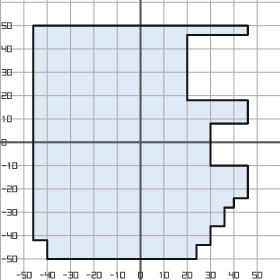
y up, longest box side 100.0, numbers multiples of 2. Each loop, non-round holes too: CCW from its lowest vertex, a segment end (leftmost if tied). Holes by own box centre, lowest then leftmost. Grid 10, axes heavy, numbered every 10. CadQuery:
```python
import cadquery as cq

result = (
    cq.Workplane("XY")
    .moveTo(-40.0, -50.0)
    .lineTo(24.0, -50.0)
    .lineTo(24.0, -44.0)
    .lineTo(30.0, -44.0)
    .lineTo(30.0, -36.0)
    .lineTo(36.0, -36.0)
    .lineTo(36.0, -28.0)
    .lineTo(40.0, -28.0)
    .lineTo(40.0, -24.0)
    .lineTo(46.0, -24.0)
    .lineTo(46.0, -10.0)
    .lineTo(30.0, -10.0)
    .lineTo(30.0, 8.0)
    .lineTo(46.0, 8.0)
    .lineTo(46.0, 18.0)
    .lineTo(20.0, 18.0)
    .lineTo(20.0, 46.0)
    .lineTo(46.0, 46.0)
    .lineTo(46.0, 50.0)
    .lineTo(-46.0, 50.0)
    .lineTo(-46.0, -42.0)
    .lineTo(-40.0, -42.0)
    .close()
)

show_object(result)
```